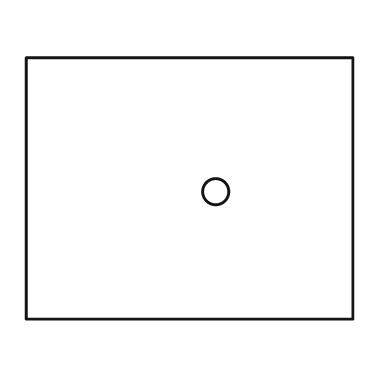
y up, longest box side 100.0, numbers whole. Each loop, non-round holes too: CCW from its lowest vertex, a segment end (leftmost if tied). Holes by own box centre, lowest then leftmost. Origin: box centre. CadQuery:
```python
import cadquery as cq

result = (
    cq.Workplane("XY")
    .moveTo(-50.0, -40.0)
    .lineTo(50.0, -40.0)
    .lineTo(50.0, 40.0)
    .lineTo(-50.0, 40.0)
    .close()
    .moveTo(8.0, -1.0)
    .circle(4.0)
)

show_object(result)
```